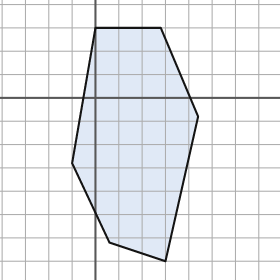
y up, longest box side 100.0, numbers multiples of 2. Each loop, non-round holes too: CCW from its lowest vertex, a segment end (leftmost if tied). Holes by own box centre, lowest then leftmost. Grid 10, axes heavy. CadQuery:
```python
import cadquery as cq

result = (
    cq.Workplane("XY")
    .moveTo(30.0, -70.0)
    .lineTo(44.0, -8.0)
    .lineTo(28.0, 30.0)
    .lineTo(0.0, 30.0)
    .lineTo(-10.0, -28.0)
    .lineTo(6.0, -62.0)
    .close()
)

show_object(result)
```